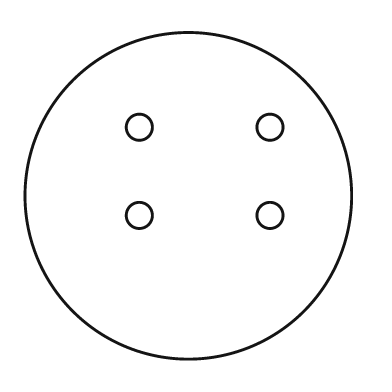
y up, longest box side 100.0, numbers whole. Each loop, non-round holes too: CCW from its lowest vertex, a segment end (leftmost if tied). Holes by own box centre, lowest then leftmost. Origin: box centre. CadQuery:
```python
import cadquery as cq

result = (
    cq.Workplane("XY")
    .moveTo(0.0, 0.0)
    .circle(50.0)
    .moveTo(-15.0, -6.0)
    .circle(4.0)
    .moveTo(25.0, -6.0)
    .circle(4.0)
    .moveTo(-15.0, 21.0)
    .circle(4.0)
    .moveTo(25.0, 21.0)
    .circle(4.0)
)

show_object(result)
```